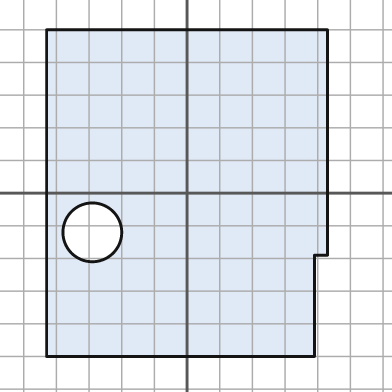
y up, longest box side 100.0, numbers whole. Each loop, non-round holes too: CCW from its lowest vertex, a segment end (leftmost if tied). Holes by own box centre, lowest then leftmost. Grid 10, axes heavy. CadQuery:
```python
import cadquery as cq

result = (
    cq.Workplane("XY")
    .moveTo(-43.0, -50.0)
    .lineTo(39.0, -50.0)
    .lineTo(39.0, -19.0)
    .lineTo(43.0, -19.0)
    .lineTo(43.0, 50.0)
    .lineTo(-43.0, 50.0)
    .close()
    .moveTo(-29.0, -12.0)
    .circle(9.0)
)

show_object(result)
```